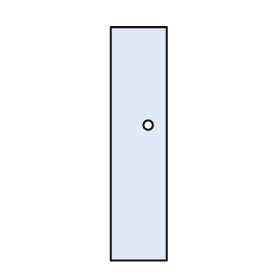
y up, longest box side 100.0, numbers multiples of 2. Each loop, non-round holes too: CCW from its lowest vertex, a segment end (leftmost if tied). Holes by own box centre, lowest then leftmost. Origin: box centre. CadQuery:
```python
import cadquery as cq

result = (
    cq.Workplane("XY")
    .moveTo(-12.0, -50.0)
    .lineTo(12.0, -50.0)
    .lineTo(12.0, 50.0)
    .lineTo(-12.0, 50.0)
    .close()
    .moveTo(4.0, 8.0)
    .circle(2.0)
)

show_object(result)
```